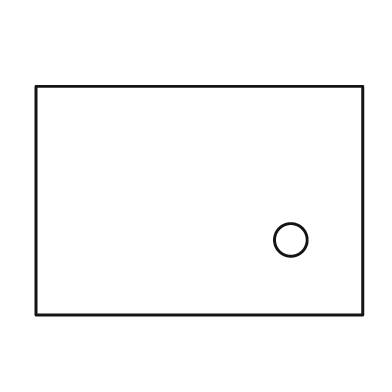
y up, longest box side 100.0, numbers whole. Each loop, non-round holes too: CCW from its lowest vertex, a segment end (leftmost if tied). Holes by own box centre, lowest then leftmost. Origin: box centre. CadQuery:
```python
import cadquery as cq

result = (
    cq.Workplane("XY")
    .moveTo(-50.0, -35.0)
    .lineTo(50.0, -35.0)
    .lineTo(50.0, 35.0)
    .lineTo(-50.0, 35.0)
    .close()
    .moveTo(28.0, -12.0)
    .circle(5.0)
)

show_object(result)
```